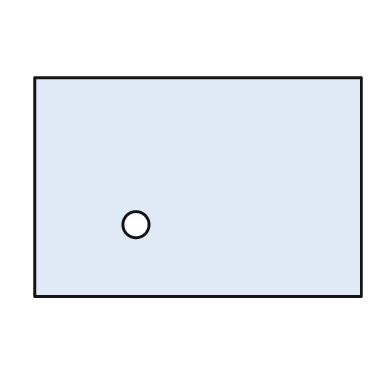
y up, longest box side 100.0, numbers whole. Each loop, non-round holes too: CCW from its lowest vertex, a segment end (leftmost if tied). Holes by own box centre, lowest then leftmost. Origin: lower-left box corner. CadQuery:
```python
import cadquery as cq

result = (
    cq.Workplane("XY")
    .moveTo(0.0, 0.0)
    .lineTo(100.0, 0.0)
    .lineTo(100.0, 67.0)
    .lineTo(0.0, 67.0)
    .close()
    .moveTo(31.0, 22.0)
    .circle(4.0)
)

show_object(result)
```